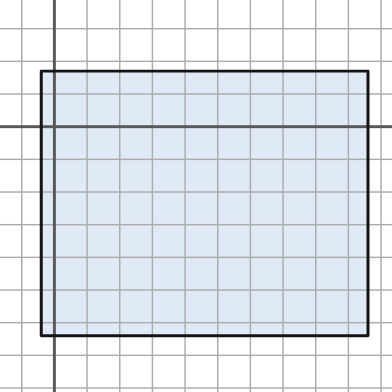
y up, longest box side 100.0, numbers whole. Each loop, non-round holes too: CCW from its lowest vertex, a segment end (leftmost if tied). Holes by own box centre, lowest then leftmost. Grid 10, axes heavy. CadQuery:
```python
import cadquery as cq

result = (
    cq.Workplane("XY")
    .moveTo(-4.0, -64.0)
    .lineTo(96.0, -64.0)
    .lineTo(96.0, 17.0)
    .lineTo(-4.0, 17.0)
    .close()
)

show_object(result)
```